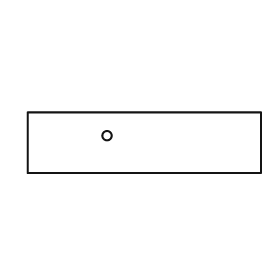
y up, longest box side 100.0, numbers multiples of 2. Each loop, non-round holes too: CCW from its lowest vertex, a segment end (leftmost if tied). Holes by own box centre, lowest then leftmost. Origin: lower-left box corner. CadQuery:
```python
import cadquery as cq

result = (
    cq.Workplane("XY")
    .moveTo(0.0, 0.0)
    .lineTo(100.0, 0.0)
    .lineTo(100.0, 26.0)
    .lineTo(0.0, 26.0)
    .close()
    .moveTo(34.0, 16.0)
    .circle(2.0)
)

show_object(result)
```